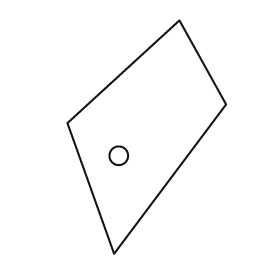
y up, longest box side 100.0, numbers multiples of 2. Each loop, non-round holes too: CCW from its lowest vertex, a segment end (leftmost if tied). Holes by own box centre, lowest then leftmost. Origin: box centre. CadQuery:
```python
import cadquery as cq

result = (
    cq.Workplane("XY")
    .moveTo(-14.0, -50.0)
    .lineTo(34.0, 14.0)
    .lineTo(14.0, 50.0)
    .lineTo(-34.0, 6.0)
    .close()
    .moveTo(-12.0, -8.0)
    .circle(4.0)
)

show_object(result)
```